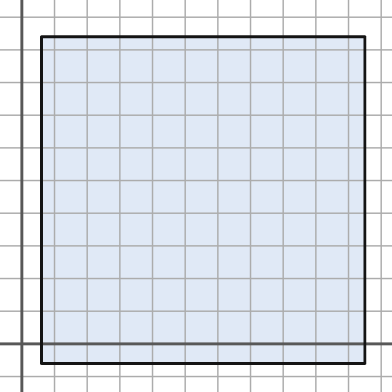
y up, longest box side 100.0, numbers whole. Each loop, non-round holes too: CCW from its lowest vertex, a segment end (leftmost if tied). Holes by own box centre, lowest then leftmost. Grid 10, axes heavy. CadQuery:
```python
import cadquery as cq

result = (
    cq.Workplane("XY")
    .moveTo(6.0, -6.0)
    .lineTo(105.0, -6.0)
    .lineTo(105.0, 94.0)
    .lineTo(6.0, 94.0)
    .close()
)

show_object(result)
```